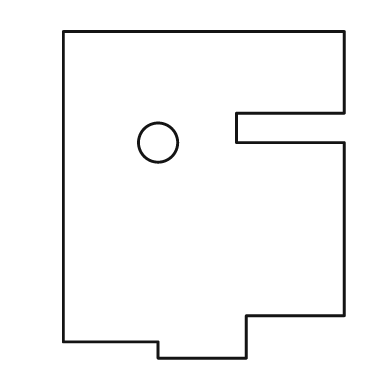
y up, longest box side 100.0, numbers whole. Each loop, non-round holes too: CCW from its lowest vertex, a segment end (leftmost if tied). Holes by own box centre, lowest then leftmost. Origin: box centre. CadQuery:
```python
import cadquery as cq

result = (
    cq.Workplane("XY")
    .moveTo(-14.0, -50.0)
    .lineTo(13.0, -50.0)
    .lineTo(13.0, -37.0)
    .lineTo(43.0, -37.0)
    .lineTo(43.0, 16.0)
    .lineTo(10.0, 16.0)
    .lineTo(10.0, 25.0)
    .lineTo(43.0, 25.0)
    .lineTo(43.0, 50.0)
    .lineTo(-43.0, 50.0)
    .lineTo(-43.0, -45.0)
    .lineTo(-14.0, -45.0)
    .close()
    .moveTo(-14.0, 16.0)
    .circle(6.0)
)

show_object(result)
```